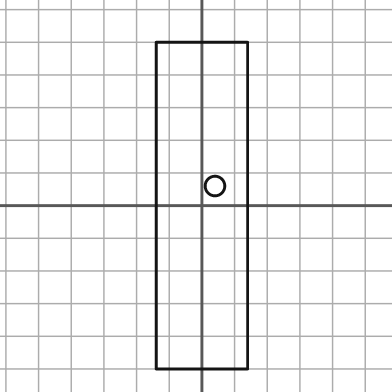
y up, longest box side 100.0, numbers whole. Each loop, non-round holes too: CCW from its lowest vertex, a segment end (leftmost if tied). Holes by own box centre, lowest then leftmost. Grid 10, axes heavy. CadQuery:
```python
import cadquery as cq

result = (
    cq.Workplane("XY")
    .moveTo(-14.0, -50.0)
    .lineTo(14.0, -50.0)
    .lineTo(14.0, 50.0)
    .lineTo(-14.0, 50.0)
    .close()
    .moveTo(4.0, 6.0)
    .circle(3.0)
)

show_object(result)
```